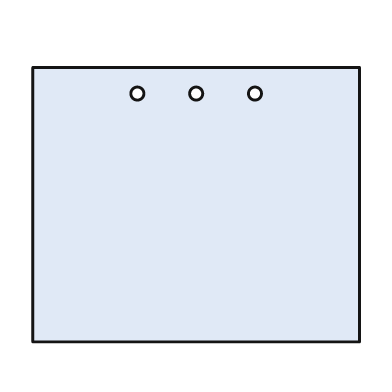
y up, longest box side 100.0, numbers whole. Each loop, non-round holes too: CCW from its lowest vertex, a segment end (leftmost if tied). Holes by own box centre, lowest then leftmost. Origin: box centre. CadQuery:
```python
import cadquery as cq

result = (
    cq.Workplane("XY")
    .moveTo(-50.0, -42.0)
    .lineTo(50.0, -42.0)
    .lineTo(50.0, 42.0)
    .lineTo(-50.0, 42.0)
    .close()
    .moveTo(-18.0, 34.0)
    .circle(2.0)
    .moveTo(0.0, 34.0)
    .circle(2.0)
    .moveTo(18.0, 34.0)
    .circle(2.0)
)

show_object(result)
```